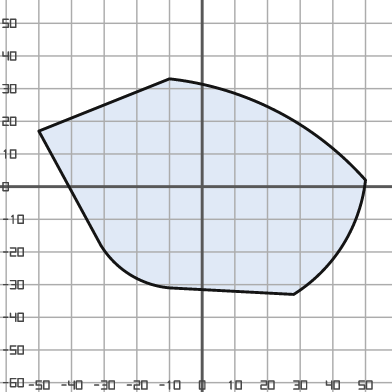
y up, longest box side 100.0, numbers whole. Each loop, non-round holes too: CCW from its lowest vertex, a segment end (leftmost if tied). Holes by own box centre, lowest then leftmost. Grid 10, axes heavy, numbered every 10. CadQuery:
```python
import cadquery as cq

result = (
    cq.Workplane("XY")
    .moveTo(28.0, -33.0)
    .threePointArc((43.0, -18.0), (50.0, 2.0))
    .threePointArc((23.0, 23.0), (-10.0, 33.0))
    .lineTo(-50.0, 17.0)
    .lineTo(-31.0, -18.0)
    .threePointArc((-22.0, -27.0), (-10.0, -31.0))
    .close()
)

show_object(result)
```